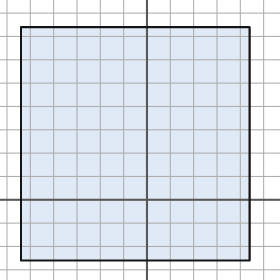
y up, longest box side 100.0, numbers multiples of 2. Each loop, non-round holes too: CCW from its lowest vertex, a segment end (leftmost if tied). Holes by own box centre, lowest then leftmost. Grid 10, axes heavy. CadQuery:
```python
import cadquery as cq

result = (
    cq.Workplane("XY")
    .moveTo(-54.0, -26.0)
    .lineTo(44.0, -26.0)
    .lineTo(44.0, 74.0)
    .lineTo(-54.0, 74.0)
    .close()
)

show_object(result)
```